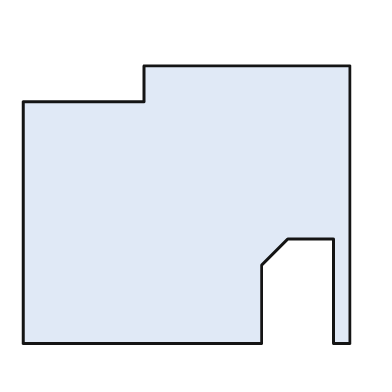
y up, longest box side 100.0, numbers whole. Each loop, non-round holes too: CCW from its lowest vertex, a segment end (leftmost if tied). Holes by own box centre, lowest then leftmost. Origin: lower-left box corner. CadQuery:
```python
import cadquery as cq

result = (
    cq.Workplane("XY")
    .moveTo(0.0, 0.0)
    .lineTo(73.0, 0.0)
    .lineTo(73.0, 24.0)
    .lineTo(81.0, 32.0)
    .lineTo(95.0, 32.0)
    .lineTo(95.0, 0.0)
    .lineTo(100.0, 0.0)
    .lineTo(100.0, 85.0)
    .lineTo(37.0, 85.0)
    .lineTo(37.0, 74.0)
    .lineTo(0.0, 74.0)
    .close()
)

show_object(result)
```